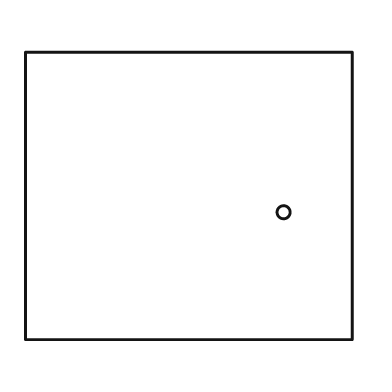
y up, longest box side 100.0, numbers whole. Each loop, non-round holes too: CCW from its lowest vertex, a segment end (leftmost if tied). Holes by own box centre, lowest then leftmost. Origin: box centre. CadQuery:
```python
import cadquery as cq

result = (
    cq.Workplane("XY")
    .moveTo(-50.0, -44.0)
    .lineTo(50.0, -44.0)
    .lineTo(50.0, 44.0)
    .lineTo(-50.0, 44.0)
    .close()
    .moveTo(29.0, -5.0)
    .circle(2.0)
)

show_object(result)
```